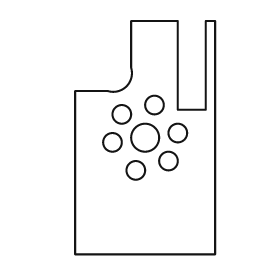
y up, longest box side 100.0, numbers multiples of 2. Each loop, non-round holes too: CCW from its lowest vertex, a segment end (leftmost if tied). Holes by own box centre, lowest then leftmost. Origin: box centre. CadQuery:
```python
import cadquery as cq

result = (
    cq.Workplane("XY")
    .moveTo(-30.0, -50.0)
    .lineTo(30.0, -50.0)
    .lineTo(30.0, 50.0)
    .lineTo(26.0, 50.0)
    .lineTo(26.0, 12.0)
    .lineTo(14.0, 12.0)
    .lineTo(14.0, 50.0)
    .lineTo(-6.0, 50.0)
    .lineTo(-6.0, 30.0)
    .threePointArc((-8.0, 22.0), (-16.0, 20.0))
    .lineTo(-30.0, 20.0)
    .close()
    .moveTo(-4.0, -14.0)
    .circle(4.0)
    .moveTo(10.0, -10.0)
    .circle(4.0)
    .moveTo(-14.0, -2.0)
    .circle(4.0)
    .moveTo(0.0, 0.0)
    .circle(6.0)
    .moveTo(14.0, 2.0)
    .circle(4.0)
    .moveTo(-10.0, 10.0)
    .circle(4.0)
    .moveTo(4.0, 14.0)
    .circle(4.0)
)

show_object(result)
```